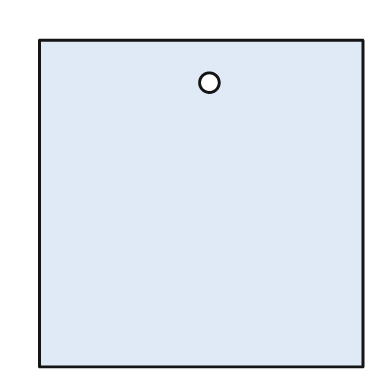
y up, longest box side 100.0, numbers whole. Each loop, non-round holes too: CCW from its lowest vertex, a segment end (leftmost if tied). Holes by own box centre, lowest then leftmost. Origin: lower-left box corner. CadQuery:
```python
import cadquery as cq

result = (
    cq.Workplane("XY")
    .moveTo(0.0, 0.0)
    .lineTo(99.0, 0.0)
    .lineTo(99.0, 100.0)
    .lineTo(0.0, 100.0)
    .close()
    .moveTo(52.0, 87.0)
    .circle(3.0)
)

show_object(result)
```